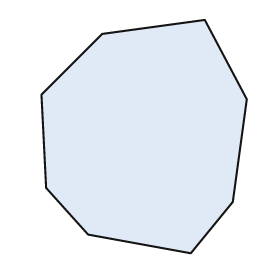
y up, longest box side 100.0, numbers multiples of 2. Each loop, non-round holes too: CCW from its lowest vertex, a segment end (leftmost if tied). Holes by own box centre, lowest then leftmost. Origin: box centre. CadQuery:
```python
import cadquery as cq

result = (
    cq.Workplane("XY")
    .moveTo(20.0, -50.0)
    .lineTo(38.0, -28.0)
    .lineTo(44.0, 16.0)
    .lineTo(26.0, 50.0)
    .lineTo(-18.0, 44.0)
    .lineTo(-44.0, 18.0)
    .lineTo(-42.0, -22.0)
    .lineTo(-24.0, -42.0)
    .close()
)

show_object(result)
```